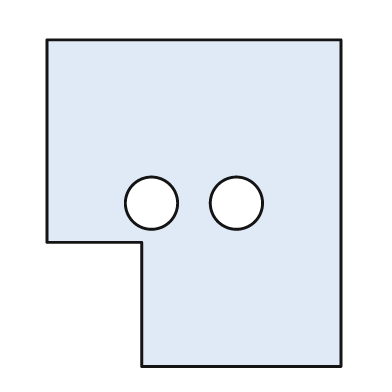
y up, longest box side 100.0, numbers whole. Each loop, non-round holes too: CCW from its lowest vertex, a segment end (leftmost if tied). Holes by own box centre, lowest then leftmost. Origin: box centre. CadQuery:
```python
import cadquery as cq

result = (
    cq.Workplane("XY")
    .moveTo(-16.0, -50.0)
    .lineTo(45.0, -50.0)
    .lineTo(45.0, 50.0)
    .lineTo(-45.0, 50.0)
    .lineTo(-45.0, -12.0)
    .lineTo(-16.0, -12.0)
    .close()
    .moveTo(-13.0, 0.0)
    .circle(8.0)
    .moveTo(13.0, 0.0)
    .circle(8.0)
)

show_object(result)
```